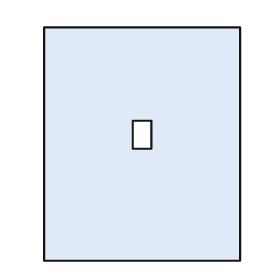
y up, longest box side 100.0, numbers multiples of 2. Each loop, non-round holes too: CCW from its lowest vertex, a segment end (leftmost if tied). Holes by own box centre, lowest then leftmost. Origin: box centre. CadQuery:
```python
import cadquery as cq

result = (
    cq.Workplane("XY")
    .moveTo(-42.0, -50.0)
    .lineTo(42.0, -50.0)
    .lineTo(42.0, 50.0)
    .lineTo(-42.0, 50.0)
    .close()
    .moveTo(-4.0, -2.0)
    .lineTo(4.0, -2.0)
    .lineTo(4.0, 10.0)
    .lineTo(-4.0, 10.0)
    .close()
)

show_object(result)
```